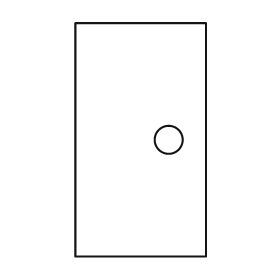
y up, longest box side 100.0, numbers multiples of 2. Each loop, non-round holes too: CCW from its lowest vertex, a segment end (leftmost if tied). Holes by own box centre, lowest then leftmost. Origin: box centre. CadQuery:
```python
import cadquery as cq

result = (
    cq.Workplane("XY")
    .moveTo(-28.0, -50.0)
    .lineTo(28.0, -50.0)
    .lineTo(28.0, 50.0)
    .lineTo(-28.0, 50.0)
    .close()
    .moveTo(12.0, 0.0)
    .circle(6.0)
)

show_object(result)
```